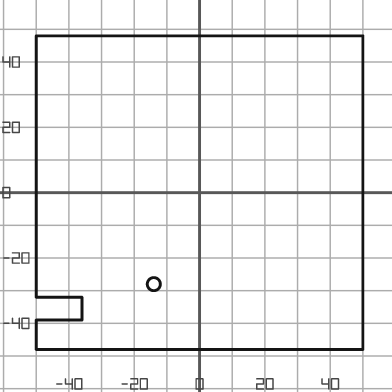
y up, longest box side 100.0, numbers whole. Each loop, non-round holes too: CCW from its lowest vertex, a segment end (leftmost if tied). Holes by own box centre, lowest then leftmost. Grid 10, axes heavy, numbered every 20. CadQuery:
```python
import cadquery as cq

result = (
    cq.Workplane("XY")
    .moveTo(-50.0, -48.0)
    .lineTo(50.0, -48.0)
    .lineTo(50.0, 48.0)
    .lineTo(-50.0, 48.0)
    .lineTo(-50.0, -32.0)
    .lineTo(-36.0, -32.0)
    .lineTo(-36.0, -39.0)
    .lineTo(-50.0, -39.0)
    .close()
    .moveTo(-14.0, -28.0)
    .circle(2.0)
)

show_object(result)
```